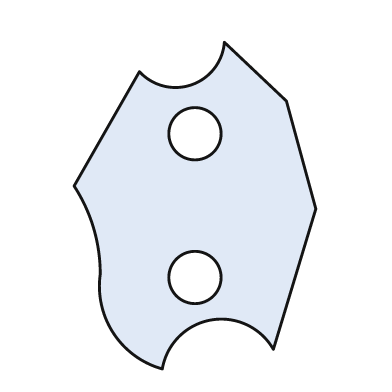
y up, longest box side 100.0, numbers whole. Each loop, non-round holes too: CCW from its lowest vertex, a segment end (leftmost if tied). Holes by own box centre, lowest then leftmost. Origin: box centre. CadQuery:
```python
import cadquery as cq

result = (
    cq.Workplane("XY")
    .moveTo(-10.0, -50.0)
    .threePointArc((5.0, -35.0), (24.0, -44.0))
    .lineTo(37.0, -1.0)
    .lineTo(28.0, 32.0)
    .lineTo(9.0, 50.0)
    .threePointArc((-1.0, 37.0), (-17.0, 41.0))
    .lineTo(-37.0, 6.0)
    .threePointArc((-31.0, -7.0), (-29.0, -21.0))
    .threePointArc((-25.0, -39.0), (-10.0, -50.0))
    .close()
    .moveTo(0.0, -22.0)
    .circle(8.0)
    .moveTo(0.0, 22.0)
    .circle(8.0)
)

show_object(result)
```